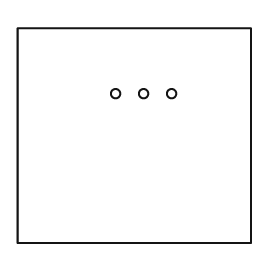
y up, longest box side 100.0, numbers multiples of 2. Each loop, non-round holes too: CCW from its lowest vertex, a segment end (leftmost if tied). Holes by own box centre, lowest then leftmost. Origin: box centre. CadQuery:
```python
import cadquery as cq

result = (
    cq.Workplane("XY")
    .moveTo(-50.0, -46.0)
    .lineTo(50.0, -46.0)
    .lineTo(50.0, 46.0)
    .lineTo(-50.0, 46.0)
    .close()
    .moveTo(-8.0, 18.0)
    .circle(2.0)
    .moveTo(4.0, 18.0)
    .circle(2.0)
    .moveTo(16.0, 18.0)
    .circle(2.0)
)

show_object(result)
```